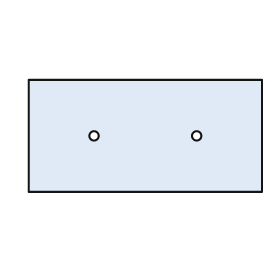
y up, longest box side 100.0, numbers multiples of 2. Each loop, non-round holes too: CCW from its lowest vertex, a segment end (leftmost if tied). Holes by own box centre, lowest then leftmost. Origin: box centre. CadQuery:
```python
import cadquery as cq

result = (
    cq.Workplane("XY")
    .moveTo(-50.0, -24.0)
    .lineTo(50.0, -24.0)
    .lineTo(50.0, 24.0)
    .lineTo(-50.0, 24.0)
    .close()
    .moveTo(-22.0, 0.0)
    .circle(2.0)
    .moveTo(22.0, 0.0)
    .circle(2.0)
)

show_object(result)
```